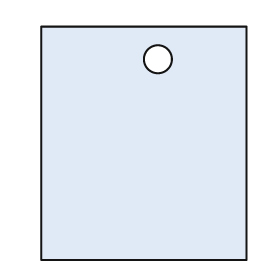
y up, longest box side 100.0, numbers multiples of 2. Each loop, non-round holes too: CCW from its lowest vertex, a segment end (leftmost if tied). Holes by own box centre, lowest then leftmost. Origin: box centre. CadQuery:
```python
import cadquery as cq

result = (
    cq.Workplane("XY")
    .moveTo(-44.0, -50.0)
    .lineTo(44.0, -50.0)
    .lineTo(44.0, 50.0)
    .lineTo(-44.0, 50.0)
    .close()
    .moveTo(6.0, 36.0)
    .circle(6.0)
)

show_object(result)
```